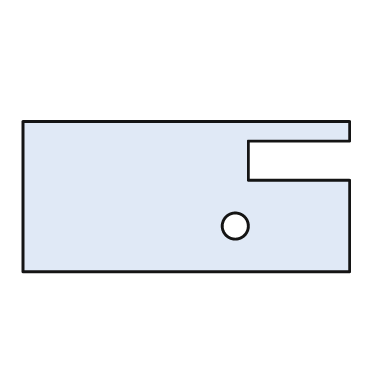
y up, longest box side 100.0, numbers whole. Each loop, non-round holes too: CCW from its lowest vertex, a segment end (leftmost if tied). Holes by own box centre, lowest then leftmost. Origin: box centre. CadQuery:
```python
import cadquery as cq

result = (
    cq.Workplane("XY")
    .moveTo(-50.0, -23.0)
    .lineTo(50.0, -23.0)
    .lineTo(50.0, 5.0)
    .lineTo(19.0, 5.0)
    .lineTo(19.0, 17.0)
    .lineTo(50.0, 17.0)
    .lineTo(50.0, 23.0)
    .lineTo(-50.0, 23.0)
    .close()
    .moveTo(15.0, -9.0)
    .circle(4.0)
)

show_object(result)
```